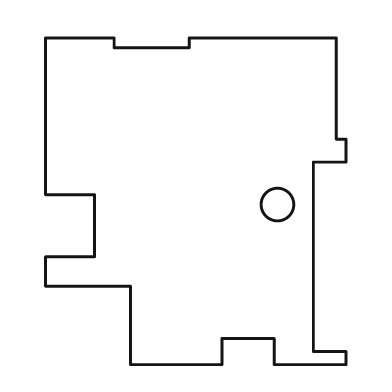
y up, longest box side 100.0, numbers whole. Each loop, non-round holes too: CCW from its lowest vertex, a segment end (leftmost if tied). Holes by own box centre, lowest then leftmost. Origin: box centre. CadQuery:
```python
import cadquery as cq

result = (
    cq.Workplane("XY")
    .moveTo(-20.0, -50.0)
    .lineTo(8.0, -50.0)
    .lineTo(8.0, -42.0)
    .lineTo(24.0, -42.0)
    .lineTo(24.0, -50.0)
    .lineTo(46.0, -50.0)
    .lineTo(46.0, -46.0)
    .lineTo(36.0, -46.0)
    .lineTo(36.0, 12.0)
    .lineTo(46.0, 12.0)
    .lineTo(46.0, 19.0)
    .lineTo(43.0, 19.0)
    .lineTo(43.0, 50.0)
    .lineTo(-2.0, 50.0)
    .lineTo(-2.0, 47.0)
    .lineTo(-25.0, 47.0)
    .lineTo(-25.0, 50.0)
    .lineTo(-46.0, 50.0)
    .lineTo(-46.0, 2.0)
    .lineTo(-31.0, 2.0)
    .lineTo(-31.0, -17.0)
    .lineTo(-46.0, -17.0)
    .lineTo(-46.0, -26.0)
    .lineTo(-20.0, -26.0)
    .close()
    .moveTo(25.0, -1.0)
    .circle(5.0)
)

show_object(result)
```